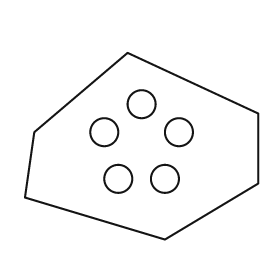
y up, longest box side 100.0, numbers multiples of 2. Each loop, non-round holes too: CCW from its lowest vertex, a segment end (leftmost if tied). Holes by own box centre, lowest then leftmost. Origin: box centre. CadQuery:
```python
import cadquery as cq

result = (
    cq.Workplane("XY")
    .moveTo(10.0, -40.0)
    .lineTo(50.0, -16.0)
    .lineTo(50.0, 14.0)
    .lineTo(-6.0, 40.0)
    .lineTo(-46.0, 6.0)
    .lineTo(-50.0, -22.0)
    .close()
    .moveTo(-10.0, -14.0)
    .circle(6.0)
    .moveTo(10.0, -14.0)
    .circle(6.0)
    .moveTo(-16.0, 6.0)
    .circle(6.0)
    .moveTo(16.0, 6.0)
    .circle(6.0)
    .moveTo(0.0, 18.0)
    .circle(6.0)
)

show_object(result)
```